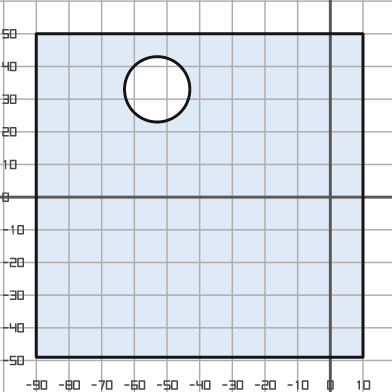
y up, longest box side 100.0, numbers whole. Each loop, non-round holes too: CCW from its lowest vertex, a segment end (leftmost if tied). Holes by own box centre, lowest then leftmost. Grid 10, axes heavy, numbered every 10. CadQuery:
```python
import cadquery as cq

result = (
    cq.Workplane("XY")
    .moveTo(-90.0, -49.0)
    .lineTo(10.0, -49.0)
    .lineTo(10.0, 50.0)
    .lineTo(-90.0, 50.0)
    .close()
    .moveTo(-53.0, 33.0)
    .circle(10.0)
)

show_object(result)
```